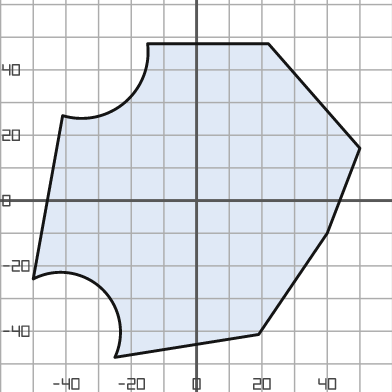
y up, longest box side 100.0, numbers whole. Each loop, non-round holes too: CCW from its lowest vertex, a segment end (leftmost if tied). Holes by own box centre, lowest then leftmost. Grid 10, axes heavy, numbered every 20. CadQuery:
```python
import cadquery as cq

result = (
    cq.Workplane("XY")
    .moveTo(-25.0, -48.0)
    .lineTo(19.0, -41.0)
    .lineTo(40.0, -10.0)
    .lineTo(50.0, 16.0)
    .lineTo(22.0, 48.0)
    .lineTo(-15.0, 48.0)
    .threePointArc((-22.0, 30.0), (-41.0, 26.0))
    .lineTo(-50.0, -24.0)
    .threePointArc((-29.0, -27.0), (-25.0, -48.0))
    .close()
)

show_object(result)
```